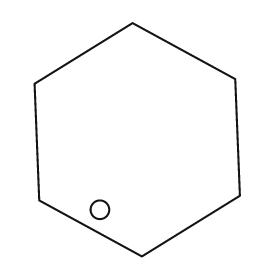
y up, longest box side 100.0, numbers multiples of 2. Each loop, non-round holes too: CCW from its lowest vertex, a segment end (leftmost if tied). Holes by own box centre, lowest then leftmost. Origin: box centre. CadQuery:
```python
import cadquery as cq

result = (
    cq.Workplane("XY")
    .moveTo(2.0, -50.0)
    .lineTo(44.0, -24.0)
    .lineTo(42.0, 26.0)
    .lineTo(-2.0, 50.0)
    .lineTo(-44.0, 24.0)
    .lineTo(-42.0, -26.0)
    .close()
    .moveTo(-16.0, -30.0)
    .circle(4.0)
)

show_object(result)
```